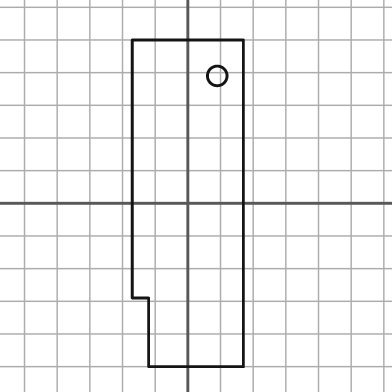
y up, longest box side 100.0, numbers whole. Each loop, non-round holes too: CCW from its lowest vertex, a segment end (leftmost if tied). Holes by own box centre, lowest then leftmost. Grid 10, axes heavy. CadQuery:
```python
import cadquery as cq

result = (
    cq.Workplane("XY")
    .moveTo(-12.0, -50.0)
    .lineTo(17.0, -50.0)
    .lineTo(17.0, 50.0)
    .lineTo(-17.0, 50.0)
    .lineTo(-17.0, -29.0)
    .lineTo(-12.0, -29.0)
    .close()
    .moveTo(9.0, 39.0)
    .circle(3.0)
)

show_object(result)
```